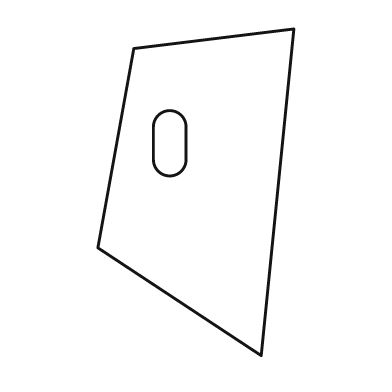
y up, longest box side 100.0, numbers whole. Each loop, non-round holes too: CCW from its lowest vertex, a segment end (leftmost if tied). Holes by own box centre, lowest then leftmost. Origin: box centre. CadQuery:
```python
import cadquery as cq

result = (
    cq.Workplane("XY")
    .moveTo(20.0, -50.0)
    .lineTo(30.0, 50.0)
    .lineTo(-19.0, 44.0)
    .lineTo(-30.0, -17.0)
    .close()
    .moveTo(-13.0, 10.0)
    .threePointArc((-8.0, 5.0), (-3.0, 10.0))
    .lineTo(-3.0, 20.0)
    .threePointArc((-8.0, 25.0), (-13.0, 20.0))
    .close()
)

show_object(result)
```